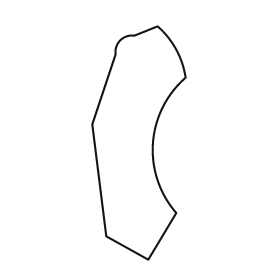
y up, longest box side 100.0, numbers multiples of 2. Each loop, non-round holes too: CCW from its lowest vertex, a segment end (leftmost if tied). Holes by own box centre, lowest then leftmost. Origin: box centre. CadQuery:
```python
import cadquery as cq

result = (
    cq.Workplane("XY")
    .moveTo(4.0, -50.0)
    .lineTo(16.0, -30.0)
    .threePointArc((6.0, 0.0), (20.0, 28.0))
    .threePointArc((16.0, 40.0), (8.0, 50.0))
    .lineTo(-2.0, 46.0)
    .threePointArc((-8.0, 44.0), (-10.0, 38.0))
    .lineTo(-20.0, 8.0)
    .lineTo(-14.0, -40.0)
    .close()
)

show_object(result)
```